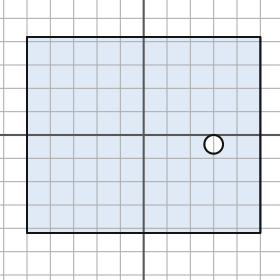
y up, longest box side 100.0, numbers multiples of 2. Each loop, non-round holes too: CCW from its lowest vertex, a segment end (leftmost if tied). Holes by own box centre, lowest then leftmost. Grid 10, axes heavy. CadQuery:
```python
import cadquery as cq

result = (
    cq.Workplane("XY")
    .moveTo(-50.0, -42.0)
    .lineTo(50.0, -42.0)
    .lineTo(50.0, 42.0)
    .lineTo(-50.0, 42.0)
    .close()
    .moveTo(30.0, -4.0)
    .circle(4.0)
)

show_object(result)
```